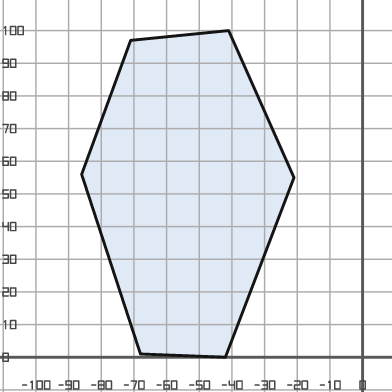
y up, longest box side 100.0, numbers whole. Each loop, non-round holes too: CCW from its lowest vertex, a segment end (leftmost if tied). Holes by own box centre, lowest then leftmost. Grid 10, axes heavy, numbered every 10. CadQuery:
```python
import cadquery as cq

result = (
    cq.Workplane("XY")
    .moveTo(-42.0, 0.0)
    .lineTo(-21.0, 55.0)
    .lineTo(-41.0, 100.0)
    .lineTo(-71.0, 97.0)
    .lineTo(-86.0, 56.0)
    .lineTo(-68.0, 1.0)
    .close()
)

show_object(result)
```